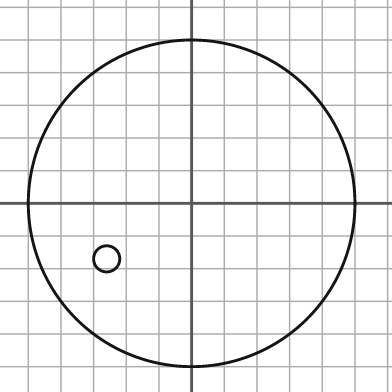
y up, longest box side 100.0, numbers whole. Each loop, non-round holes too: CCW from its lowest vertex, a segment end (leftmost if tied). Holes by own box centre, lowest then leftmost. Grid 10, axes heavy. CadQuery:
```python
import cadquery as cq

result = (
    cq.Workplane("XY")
    .moveTo(0.0, 0.0)
    .circle(50.0)
    .moveTo(-26.0, -17.0)
    .circle(4.0)
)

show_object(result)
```